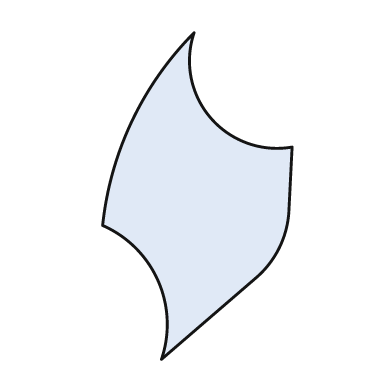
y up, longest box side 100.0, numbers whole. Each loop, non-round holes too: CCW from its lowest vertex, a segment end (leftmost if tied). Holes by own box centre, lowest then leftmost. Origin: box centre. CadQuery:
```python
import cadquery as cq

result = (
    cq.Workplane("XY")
    .moveTo(-11.0, -50.0)
    .lineTo(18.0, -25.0)
    .threePointArc((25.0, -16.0), (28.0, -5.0))
    .lineTo(29.0, 15.0)
    .threePointArc((4.0, 24.0), (-1.0, 50.0))
    .threePointArc((-20.0, 23.0), (-29.0, -9.0))
    .threePointArc((-12.0, -26.0), (-11.0, -50.0))
    .close()
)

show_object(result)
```